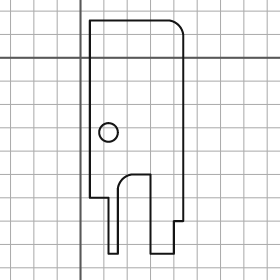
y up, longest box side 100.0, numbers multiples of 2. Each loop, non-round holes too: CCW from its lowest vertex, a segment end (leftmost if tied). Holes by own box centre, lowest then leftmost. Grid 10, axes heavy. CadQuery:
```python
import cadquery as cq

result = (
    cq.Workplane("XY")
    .moveTo(12.0, -84.0)
    .lineTo(16.0, -84.0)
    .lineTo(16.0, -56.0)
    .threePointArc((18.0, -52.0), (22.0, -50.0))
    .lineTo(30.0, -50.0)
    .lineTo(30.0, -84.0)
    .lineTo(40.0, -84.0)
    .lineTo(40.0, -70.0)
    .lineTo(44.0, -70.0)
    .lineTo(44.0, 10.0)
    .threePointArc((42.0, 14.0), (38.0, 16.0))
    .lineTo(4.0, 16.0)
    .lineTo(4.0, -60.0)
    .lineTo(12.0, -60.0)
    .close()
    .moveTo(12.0, -32.0)
    .circle(4.0)
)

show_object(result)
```